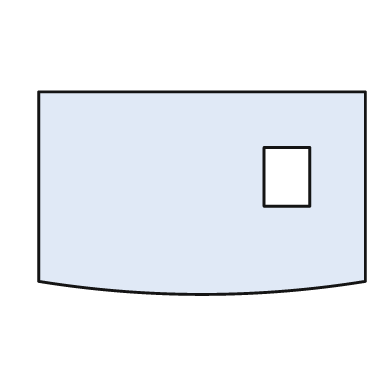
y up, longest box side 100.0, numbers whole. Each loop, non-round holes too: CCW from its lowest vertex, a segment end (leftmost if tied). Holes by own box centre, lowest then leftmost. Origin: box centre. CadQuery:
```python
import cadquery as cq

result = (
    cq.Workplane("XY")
    .moveTo(-50.0, -27.0)
    .threePointArc((0.0, -31.0), (50.0, -27.0))
    .lineTo(50.0, 31.0)
    .lineTo(-50.0, 31.0)
    .close()
    .moveTo(19.0, -4.0)
    .lineTo(33.0, -4.0)
    .lineTo(33.0, 14.0)
    .lineTo(19.0, 14.0)
    .close()
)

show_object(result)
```